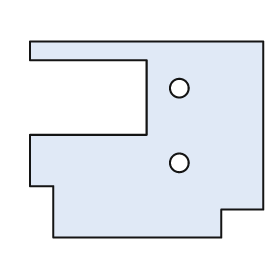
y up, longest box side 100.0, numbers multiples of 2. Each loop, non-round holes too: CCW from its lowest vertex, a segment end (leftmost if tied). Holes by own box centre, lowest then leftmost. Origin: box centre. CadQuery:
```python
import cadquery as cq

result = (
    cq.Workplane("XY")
    .moveTo(-40.0, -42.0)
    .lineTo(32.0, -42.0)
    .lineTo(32.0, -30.0)
    .lineTo(50.0, -30.0)
    .lineTo(50.0, 42.0)
    .lineTo(-50.0, 42.0)
    .lineTo(-50.0, 34.0)
    .lineTo(0.0, 34.0)
    .lineTo(0.0, 2.0)
    .lineTo(-50.0, 2.0)
    .lineTo(-50.0, -20.0)
    .lineTo(-40.0, -20.0)
    .close()
    .moveTo(14.0, -10.0)
    .circle(4.0)
    .moveTo(14.0, 22.0)
    .circle(4.0)
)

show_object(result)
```